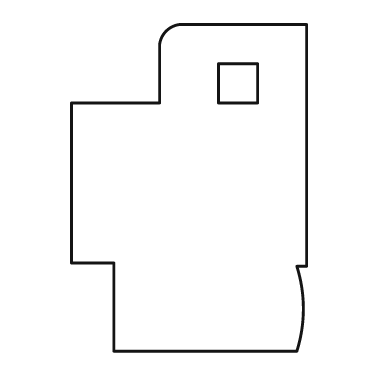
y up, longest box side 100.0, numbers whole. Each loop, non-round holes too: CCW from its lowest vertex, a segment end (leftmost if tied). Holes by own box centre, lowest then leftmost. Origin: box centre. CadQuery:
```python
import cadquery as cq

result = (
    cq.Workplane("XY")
    .moveTo(-23.0, -50.0)
    .lineTo(33.0, -50.0)
    .threePointArc((35.0, -37.0), (33.0, -24.0))
    .lineTo(36.0, -24.0)
    .lineTo(36.0, 50.0)
    .lineTo(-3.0, 50.0)
    .threePointArc((-7.0, 48.0), (-9.0, 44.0))
    .lineTo(-9.0, 26.0)
    .lineTo(-36.0, 26.0)
    .lineTo(-36.0, -23.0)
    .lineTo(-23.0, -23.0)
    .close()
    .moveTo(9.0, 26.0)
    .lineTo(21.0, 26.0)
    .lineTo(21.0, 38.0)
    .lineTo(9.0, 38.0)
    .close()
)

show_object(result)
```